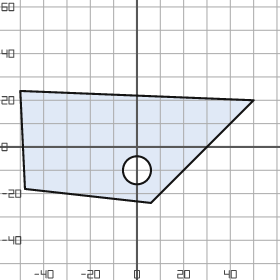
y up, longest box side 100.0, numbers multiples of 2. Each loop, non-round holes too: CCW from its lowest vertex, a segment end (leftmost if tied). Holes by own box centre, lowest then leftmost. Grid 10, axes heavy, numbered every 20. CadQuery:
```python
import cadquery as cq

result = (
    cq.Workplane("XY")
    .moveTo(6.0, -24.0)
    .lineTo(50.0, 20.0)
    .lineTo(-50.0, 24.0)
    .lineTo(-48.0, -18.0)
    .close()
    .moveTo(0.0, -10.0)
    .circle(6.0)
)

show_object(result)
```